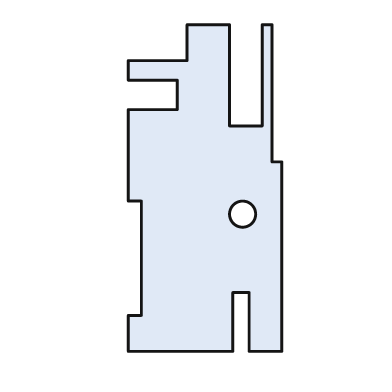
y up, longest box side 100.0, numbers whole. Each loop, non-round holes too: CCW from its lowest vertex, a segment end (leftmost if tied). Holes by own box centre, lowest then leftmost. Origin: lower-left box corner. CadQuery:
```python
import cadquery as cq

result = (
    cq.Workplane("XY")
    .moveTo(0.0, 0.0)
    .lineTo(32.0, 0.0)
    .lineTo(32.0, 18.0)
    .lineTo(37.0, 18.0)
    .lineTo(37.0, 0.0)
    .lineTo(47.0, 0.0)
    .lineTo(47.0, 58.0)
    .lineTo(44.0, 58.0)
    .lineTo(44.0, 100.0)
    .lineTo(41.0, 100.0)
    .lineTo(41.0, 69.0)
    .lineTo(31.0, 69.0)
    .lineTo(31.0, 100.0)
    .lineTo(18.0, 100.0)
    .lineTo(18.0, 89.0)
    .lineTo(0.0, 89.0)
    .lineTo(0.0, 83.0)
    .lineTo(15.0, 83.0)
    .lineTo(15.0, 74.0)
    .lineTo(0.0, 74.0)
    .lineTo(0.0, 46.0)
    .lineTo(4.0, 46.0)
    .lineTo(4.0, 11.0)
    .lineTo(0.0, 11.0)
    .close()
    .moveTo(35.0, 42.0)
    .circle(4.0)
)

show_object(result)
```